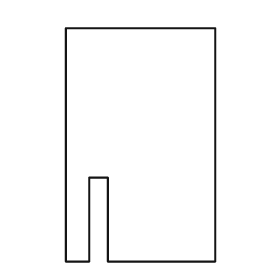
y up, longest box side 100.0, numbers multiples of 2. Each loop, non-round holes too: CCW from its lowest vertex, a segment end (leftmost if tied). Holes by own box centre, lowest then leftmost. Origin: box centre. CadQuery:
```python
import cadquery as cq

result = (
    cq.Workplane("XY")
    .moveTo(-32.0, -50.0)
    .lineTo(-22.0, -50.0)
    .lineTo(-22.0, -14.0)
    .lineTo(-14.0, -14.0)
    .lineTo(-14.0, -50.0)
    .lineTo(32.0, -50.0)
    .lineTo(32.0, 50.0)
    .lineTo(-32.0, 50.0)
    .close()
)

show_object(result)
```